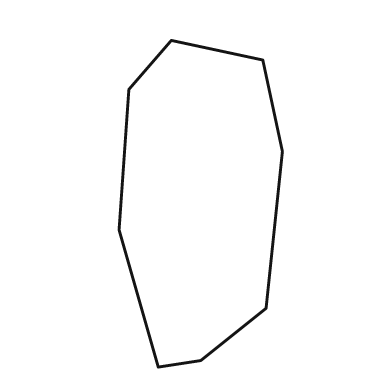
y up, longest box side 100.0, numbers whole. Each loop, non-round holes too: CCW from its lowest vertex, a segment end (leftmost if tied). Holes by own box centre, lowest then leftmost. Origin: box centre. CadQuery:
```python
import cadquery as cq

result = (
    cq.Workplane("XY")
    .moveTo(-13.0, -50.0)
    .lineTo(0.0, -48.0)
    .lineTo(20.0, -32.0)
    .lineTo(25.0, 16.0)
    .lineTo(19.0, 44.0)
    .lineTo(-9.0, 50.0)
    .lineTo(-22.0, 35.0)
    .lineTo(-25.0, -8.0)
    .close()
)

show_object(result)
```